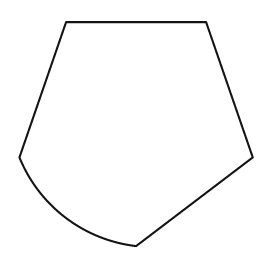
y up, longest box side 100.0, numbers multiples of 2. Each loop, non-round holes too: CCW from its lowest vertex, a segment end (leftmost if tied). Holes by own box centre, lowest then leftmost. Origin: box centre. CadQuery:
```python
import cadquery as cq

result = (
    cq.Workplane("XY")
    .moveTo(0.0, -48.0)
    .lineTo(50.0, -10.0)
    .lineTo(30.0, 48.0)
    .lineTo(-30.0, 48.0)
    .lineTo(-50.0, -10.0)
    .threePointArc((-30.0, -36.0), (0.0, -48.0))
    .close()
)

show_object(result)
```